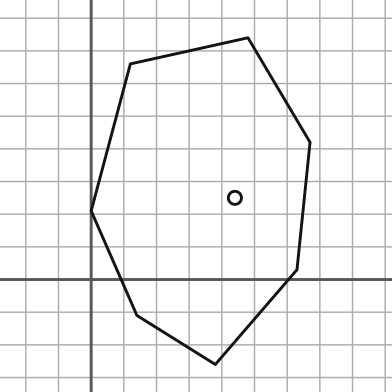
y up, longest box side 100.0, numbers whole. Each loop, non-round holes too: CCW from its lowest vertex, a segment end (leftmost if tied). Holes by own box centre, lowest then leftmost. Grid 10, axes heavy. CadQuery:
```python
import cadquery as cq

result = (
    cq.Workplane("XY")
    .moveTo(38.0, -26.0)
    .lineTo(63.0, 3.0)
    .lineTo(67.0, 42.0)
    .lineTo(48.0, 74.0)
    .lineTo(12.0, 66.0)
    .lineTo(0.0, 21.0)
    .lineTo(14.0, -11.0)
    .close()
    .moveTo(44.0, 25.0)
    .circle(2.0)
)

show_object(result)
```